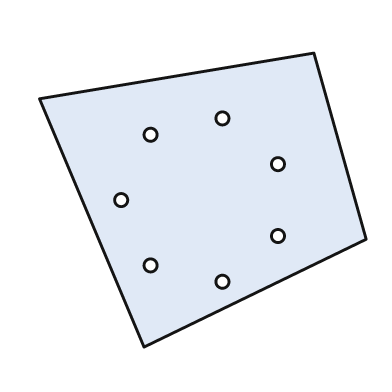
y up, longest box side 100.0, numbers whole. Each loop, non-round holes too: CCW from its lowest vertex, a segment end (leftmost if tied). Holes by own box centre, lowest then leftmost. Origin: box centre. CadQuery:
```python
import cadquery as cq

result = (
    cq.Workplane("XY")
    .moveTo(-18.0, -45.0)
    .lineTo(50.0, -12.0)
    .lineTo(34.0, 45.0)
    .lineTo(-50.0, 31.0)
    .close()
    .moveTo(6.0, -25.0)
    .circle(2.0)
    .moveTo(-16.0, -20.0)
    .circle(2.0)
    .moveTo(23.0, -11.0)
    .circle(2.0)
    .moveTo(-25.0, 0.0)
    .circle(2.0)
    .moveTo(23.0, 11.0)
    .circle(2.0)
    .moveTo(-16.0, 20.0)
    .circle(2.0)
    .moveTo(6.0, 25.0)
    .circle(2.0)
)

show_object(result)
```